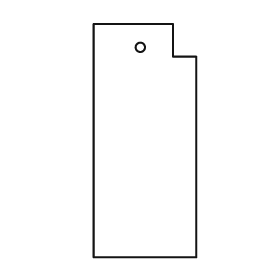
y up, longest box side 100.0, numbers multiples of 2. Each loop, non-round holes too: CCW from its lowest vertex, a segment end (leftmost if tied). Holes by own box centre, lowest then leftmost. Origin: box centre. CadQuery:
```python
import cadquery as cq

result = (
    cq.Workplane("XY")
    .moveTo(-22.0, -50.0)
    .lineTo(22.0, -50.0)
    .lineTo(22.0, 36.0)
    .lineTo(12.0, 36.0)
    .lineTo(12.0, 50.0)
    .lineTo(-22.0, 50.0)
    .close()
    .moveTo(-2.0, 40.0)
    .circle(2.0)
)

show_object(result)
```